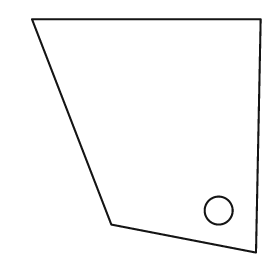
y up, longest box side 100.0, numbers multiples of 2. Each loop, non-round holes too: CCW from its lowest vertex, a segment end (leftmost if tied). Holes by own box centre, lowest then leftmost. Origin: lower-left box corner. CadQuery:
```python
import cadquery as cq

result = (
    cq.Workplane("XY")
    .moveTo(96.0, 0.0)
    .lineTo(98.0, 100.0)
    .lineTo(0.0, 100.0)
    .lineTo(34.0, 12.0)
    .close()
    .moveTo(80.0, 18.0)
    .circle(6.0)
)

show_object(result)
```